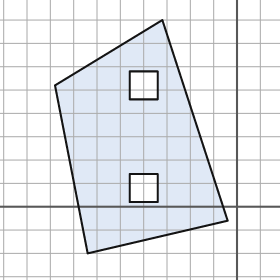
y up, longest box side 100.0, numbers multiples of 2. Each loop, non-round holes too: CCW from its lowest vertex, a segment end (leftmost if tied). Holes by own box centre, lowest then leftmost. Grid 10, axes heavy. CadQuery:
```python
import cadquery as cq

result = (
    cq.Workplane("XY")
    .moveTo(-64.0, -20.0)
    .lineTo(-4.0, -6.0)
    .lineTo(-32.0, 80.0)
    .lineTo(-78.0, 52.0)
    .close()
    .moveTo(-46.0, 2.0)
    .lineTo(-34.0, 2.0)
    .lineTo(-34.0, 14.0)
    .lineTo(-46.0, 14.0)
    .close()
    .moveTo(-46.0, 46.0)
    .lineTo(-34.0, 46.0)
    .lineTo(-34.0, 58.0)
    .lineTo(-46.0, 58.0)
    .close()
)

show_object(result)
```